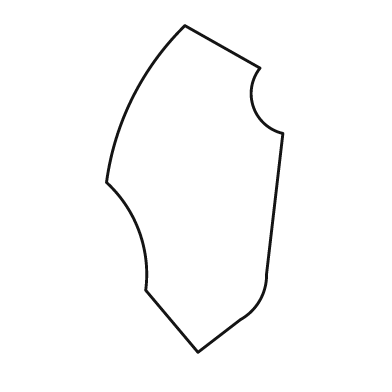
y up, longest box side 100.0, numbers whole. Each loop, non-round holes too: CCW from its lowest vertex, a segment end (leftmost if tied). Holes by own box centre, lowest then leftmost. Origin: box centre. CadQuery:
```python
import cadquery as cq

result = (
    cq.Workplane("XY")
    .moveTo(1.0, -50.0)
    .lineTo(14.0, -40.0)
    .threePointArc((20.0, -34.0), (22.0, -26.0))
    .lineTo(27.0, 17.0)
    .threePointArc((18.0, 25.0), (20.0, 37.0))
    .lineTo(-3.0, 50.0)
    .threePointArc((-19.0, 28.0), (-27.0, 2.0))
    .threePointArc((-17.0, -13.0), (-15.0, -31.0))
    .close()
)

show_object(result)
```